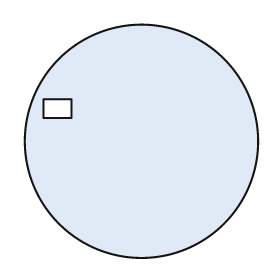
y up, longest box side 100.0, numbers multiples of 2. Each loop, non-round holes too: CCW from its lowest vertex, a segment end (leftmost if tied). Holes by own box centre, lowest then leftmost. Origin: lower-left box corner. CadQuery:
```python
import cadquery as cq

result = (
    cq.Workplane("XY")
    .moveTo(50.0, 50.0)
    .circle(50.0)
    .moveTo(8.0, 60.0)
    .lineTo(20.0, 60.0)
    .lineTo(20.0, 68.0)
    .lineTo(8.0, 68.0)
    .close()
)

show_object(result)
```